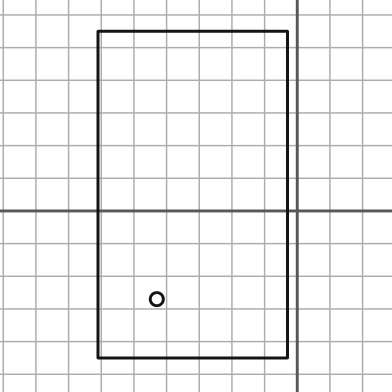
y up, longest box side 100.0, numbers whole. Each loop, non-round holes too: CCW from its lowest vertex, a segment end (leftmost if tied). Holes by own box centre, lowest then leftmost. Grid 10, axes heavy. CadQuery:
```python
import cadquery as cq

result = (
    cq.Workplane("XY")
    .moveTo(-61.0, -45.0)
    .lineTo(-3.0, -45.0)
    .lineTo(-3.0, 55.0)
    .lineTo(-61.0, 55.0)
    .close()
    .moveTo(-43.0, -27.0)
    .circle(2.0)
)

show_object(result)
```